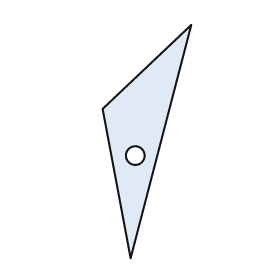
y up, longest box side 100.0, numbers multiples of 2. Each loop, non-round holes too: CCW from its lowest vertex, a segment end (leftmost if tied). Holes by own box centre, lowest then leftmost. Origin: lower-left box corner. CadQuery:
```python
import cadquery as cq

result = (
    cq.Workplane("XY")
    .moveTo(12.0, 0.0)
    .lineTo(38.0, 100.0)
    .lineTo(0.0, 64.0)
    .close()
    .moveTo(14.0, 44.0)
    .circle(4.0)
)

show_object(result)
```